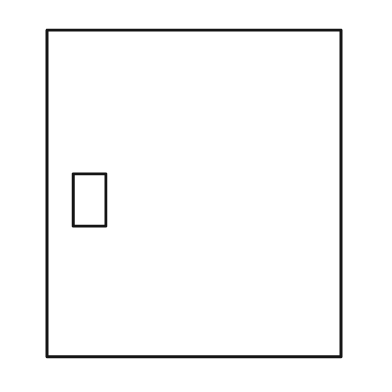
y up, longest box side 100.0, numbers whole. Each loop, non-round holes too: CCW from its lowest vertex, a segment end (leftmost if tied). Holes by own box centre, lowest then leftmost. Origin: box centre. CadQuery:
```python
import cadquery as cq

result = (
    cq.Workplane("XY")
    .moveTo(-45.0, -50.0)
    .lineTo(45.0, -50.0)
    .lineTo(45.0, 50.0)
    .lineTo(-45.0, 50.0)
    .close()
    .moveTo(-37.0, -10.0)
    .lineTo(-27.0, -10.0)
    .lineTo(-27.0, 6.0)
    .lineTo(-37.0, 6.0)
    .close()
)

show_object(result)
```